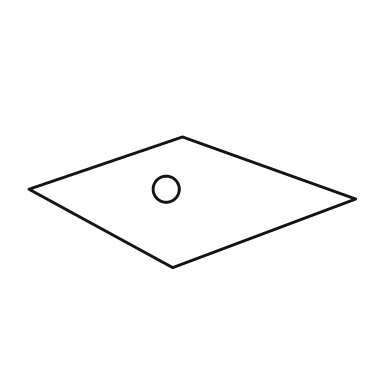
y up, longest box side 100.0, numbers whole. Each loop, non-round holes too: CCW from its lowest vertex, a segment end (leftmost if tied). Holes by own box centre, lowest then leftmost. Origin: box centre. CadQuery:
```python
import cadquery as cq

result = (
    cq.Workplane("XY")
    .moveTo(-6.0, -20.0)
    .lineTo(50.0, 1.0)
    .lineTo(-3.0, 20.0)
    .lineTo(-50.0, 4.0)
    .close()
    .moveTo(-8.0, 4.0)
    .circle(4.0)
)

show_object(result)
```